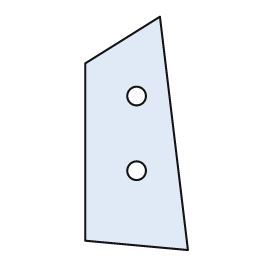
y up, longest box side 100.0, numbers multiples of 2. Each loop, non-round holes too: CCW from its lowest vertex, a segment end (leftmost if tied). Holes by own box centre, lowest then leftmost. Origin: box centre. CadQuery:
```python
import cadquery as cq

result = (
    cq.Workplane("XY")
    .moveTo(22.0, -50.0)
    .lineTo(10.0, 50.0)
    .lineTo(-22.0, 30.0)
    .lineTo(-22.0, -46.0)
    .close()
    .moveTo(0.0, -16.0)
    .circle(4.0)
    .moveTo(0.0, 16.0)
    .circle(4.0)
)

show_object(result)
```